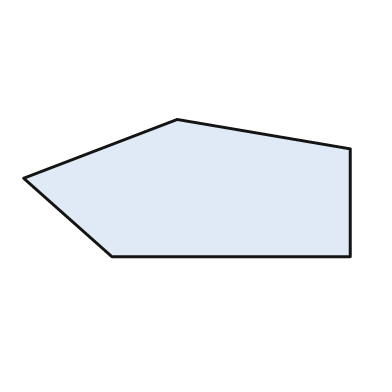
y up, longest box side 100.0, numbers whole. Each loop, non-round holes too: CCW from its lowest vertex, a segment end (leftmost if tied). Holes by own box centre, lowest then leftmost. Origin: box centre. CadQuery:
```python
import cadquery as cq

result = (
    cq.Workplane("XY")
    .moveTo(-23.0, -21.0)
    .lineTo(50.0, -21.0)
    .lineTo(50.0, 12.0)
    .lineTo(-3.0, 21.0)
    .lineTo(-50.0, 3.0)
    .close()
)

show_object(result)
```